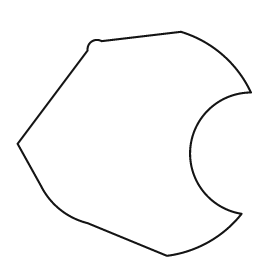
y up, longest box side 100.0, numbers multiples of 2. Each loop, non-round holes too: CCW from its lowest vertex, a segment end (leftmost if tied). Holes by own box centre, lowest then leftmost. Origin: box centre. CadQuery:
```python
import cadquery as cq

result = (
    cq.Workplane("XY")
    .moveTo(14.0, -48.0)
    .threePointArc((32.0, -42.0), (46.0, -30.0))
    .threePointArc((24.0, -2.0), (50.0, 22.0))
    .threePointArc((38.0, 38.0), (20.0, 48.0))
    .lineTo(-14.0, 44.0)
    .threePointArc((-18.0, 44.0), (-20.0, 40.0))
    .lineTo(-50.0, 0.0)
    .lineTo(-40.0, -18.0)
    .threePointArc((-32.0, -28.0), (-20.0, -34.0))
    .close()
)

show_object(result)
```